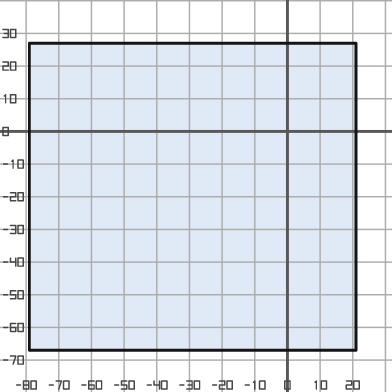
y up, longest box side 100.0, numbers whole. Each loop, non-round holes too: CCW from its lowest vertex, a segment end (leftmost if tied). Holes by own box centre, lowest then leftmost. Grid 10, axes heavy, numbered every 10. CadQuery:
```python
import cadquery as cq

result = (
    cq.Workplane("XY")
    .moveTo(-79.0, -67.0)
    .lineTo(21.0, -67.0)
    .lineTo(21.0, 27.0)
    .lineTo(-79.0, 27.0)
    .close()
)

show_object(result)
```